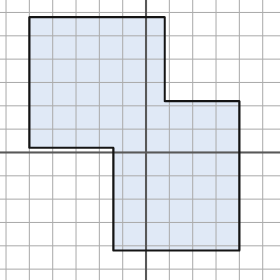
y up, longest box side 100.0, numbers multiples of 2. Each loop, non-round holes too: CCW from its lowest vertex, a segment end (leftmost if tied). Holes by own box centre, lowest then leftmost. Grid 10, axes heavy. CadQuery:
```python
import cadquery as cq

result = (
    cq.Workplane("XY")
    .moveTo(-14.0, -42.0)
    .lineTo(40.0, -42.0)
    .lineTo(40.0, 22.0)
    .lineTo(8.0, 22.0)
    .lineTo(8.0, 58.0)
    .lineTo(-50.0, 58.0)
    .lineTo(-50.0, 2.0)
    .lineTo(-14.0, 2.0)
    .close()
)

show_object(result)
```